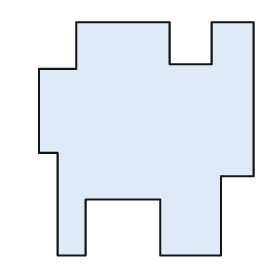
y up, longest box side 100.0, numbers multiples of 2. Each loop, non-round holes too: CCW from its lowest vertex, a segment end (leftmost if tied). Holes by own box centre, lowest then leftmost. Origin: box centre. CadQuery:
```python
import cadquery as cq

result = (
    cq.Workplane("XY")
    .moveTo(-38.0, -50.0)
    .lineTo(-26.0, -50.0)
    .lineTo(-26.0, -26.0)
    .lineTo(6.0, -26.0)
    .lineTo(6.0, -50.0)
    .lineTo(32.0, -50.0)
    .lineTo(32.0, -16.0)
    .lineTo(46.0, -16.0)
    .lineTo(46.0, 50.0)
    .lineTo(28.0, 50.0)
    .lineTo(28.0, 32.0)
    .lineTo(10.0, 32.0)
    .lineTo(10.0, 50.0)
    .lineTo(-30.0, 50.0)
    .lineTo(-30.0, 30.0)
    .lineTo(-46.0, 30.0)
    .lineTo(-46.0, -6.0)
    .lineTo(-38.0, -6.0)
    .close()
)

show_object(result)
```